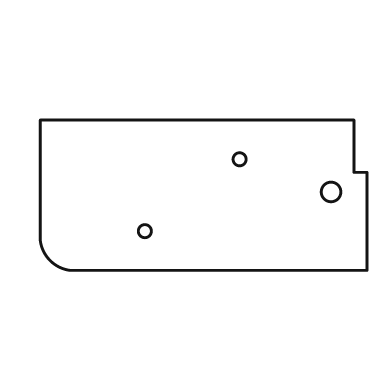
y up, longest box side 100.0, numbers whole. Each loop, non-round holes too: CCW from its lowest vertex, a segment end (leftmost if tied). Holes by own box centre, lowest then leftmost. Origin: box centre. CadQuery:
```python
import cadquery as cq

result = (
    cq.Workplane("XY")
    .moveTo(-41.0, -23.0)
    .lineTo(50.0, -23.0)
    .lineTo(50.0, 7.0)
    .lineTo(46.0, 7.0)
    .lineTo(46.0, 23.0)
    .lineTo(-50.0, 23.0)
    .lineTo(-50.0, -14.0)
    .threePointArc((-47.0, -20.0), (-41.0, -23.0))
    .close()
    .moveTo(-18.0, -11.0)
    .circle(2.0)
    .moveTo(39.0, 1.0)
    .circle(3.0)
    .moveTo(11.0, 11.0)
    .circle(2.0)
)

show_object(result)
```